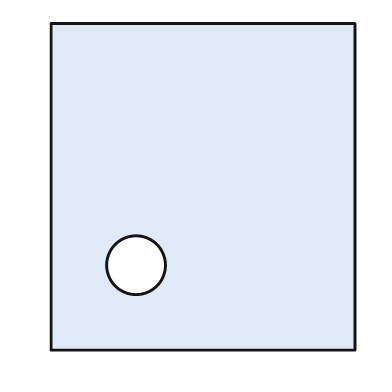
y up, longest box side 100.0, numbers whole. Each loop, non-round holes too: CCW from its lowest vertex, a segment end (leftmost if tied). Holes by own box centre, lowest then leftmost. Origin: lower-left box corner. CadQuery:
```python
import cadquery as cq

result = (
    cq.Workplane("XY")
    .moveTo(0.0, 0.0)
    .lineTo(93.0, 0.0)
    .lineTo(93.0, 100.0)
    .lineTo(0.0, 100.0)
    .close()
    .moveTo(26.0, 26.0)
    .circle(9.0)
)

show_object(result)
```